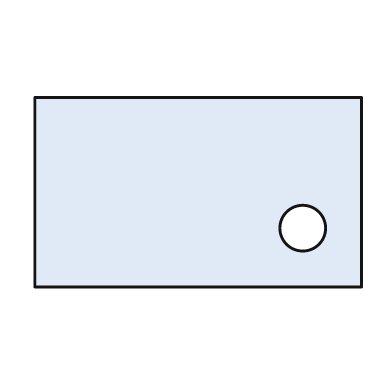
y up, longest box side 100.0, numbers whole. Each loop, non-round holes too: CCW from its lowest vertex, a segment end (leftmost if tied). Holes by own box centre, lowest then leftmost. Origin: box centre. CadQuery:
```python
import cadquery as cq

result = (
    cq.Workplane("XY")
    .moveTo(-50.0, -29.0)
    .lineTo(50.0, -29.0)
    .lineTo(50.0, 29.0)
    .lineTo(-50.0, 29.0)
    .close()
    .moveTo(32.0, -11.0)
    .circle(7.0)
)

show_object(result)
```